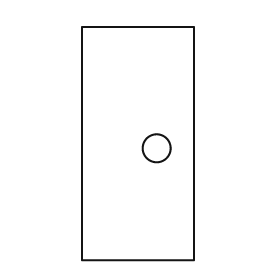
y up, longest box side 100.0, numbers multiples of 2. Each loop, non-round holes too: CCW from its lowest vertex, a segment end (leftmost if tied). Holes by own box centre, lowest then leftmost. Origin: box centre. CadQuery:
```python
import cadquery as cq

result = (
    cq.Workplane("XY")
    .moveTo(-24.0, -50.0)
    .lineTo(24.0, -50.0)
    .lineTo(24.0, 50.0)
    .lineTo(-24.0, 50.0)
    .close()
    .moveTo(8.0, -2.0)
    .circle(6.0)
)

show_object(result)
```